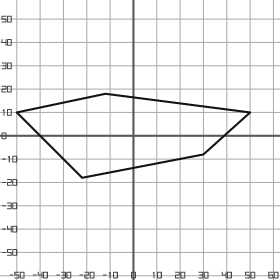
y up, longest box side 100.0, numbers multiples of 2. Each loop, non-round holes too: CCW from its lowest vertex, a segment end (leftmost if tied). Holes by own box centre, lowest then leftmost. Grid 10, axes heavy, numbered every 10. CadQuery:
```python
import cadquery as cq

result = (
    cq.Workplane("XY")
    .moveTo(-22.0, -18.0)
    .lineTo(30.0, -8.0)
    .lineTo(50.0, 10.0)
    .lineTo(-12.0, 18.0)
    .lineTo(-50.0, 10.0)
    .close()
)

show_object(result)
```